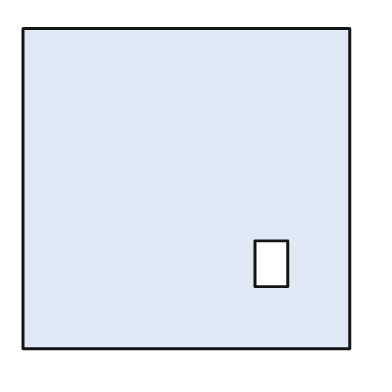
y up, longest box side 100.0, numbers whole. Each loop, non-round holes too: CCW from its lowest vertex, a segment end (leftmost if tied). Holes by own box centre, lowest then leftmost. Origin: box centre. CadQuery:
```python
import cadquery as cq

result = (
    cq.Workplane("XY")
    .moveTo(-50.0, -49.0)
    .lineTo(50.0, -49.0)
    .lineTo(50.0, 49.0)
    .lineTo(-50.0, 49.0)
    .close()
    .moveTo(21.0, -30.0)
    .lineTo(31.0, -30.0)
    .lineTo(31.0, -16.0)
    .lineTo(21.0, -16.0)
    .close()
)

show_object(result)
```